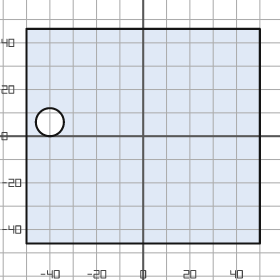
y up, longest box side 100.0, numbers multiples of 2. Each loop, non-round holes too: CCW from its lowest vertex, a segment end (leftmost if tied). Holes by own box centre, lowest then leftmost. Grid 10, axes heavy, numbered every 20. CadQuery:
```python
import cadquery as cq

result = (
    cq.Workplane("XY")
    .moveTo(-50.0, -46.0)
    .lineTo(50.0, -46.0)
    .lineTo(50.0, 46.0)
    .lineTo(-50.0, 46.0)
    .close()
    .moveTo(-40.0, 6.0)
    .circle(6.0)
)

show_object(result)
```